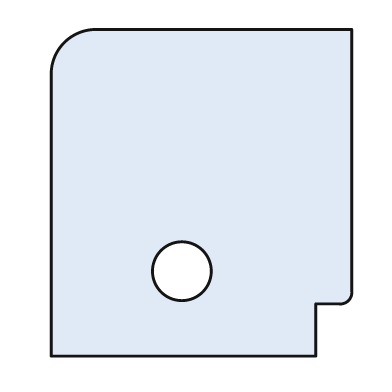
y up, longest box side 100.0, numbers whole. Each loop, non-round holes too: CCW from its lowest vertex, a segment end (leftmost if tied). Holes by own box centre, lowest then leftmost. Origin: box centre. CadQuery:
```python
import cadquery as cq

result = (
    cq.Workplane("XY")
    .moveTo(-46.0, -50.0)
    .lineTo(35.0, -50.0)
    .lineTo(35.0, -34.0)
    .lineTo(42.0, -34.0)
    .threePointArc((45.0, -33.0), (46.0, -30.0))
    .lineTo(46.0, 50.0)
    .lineTo(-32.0, 50.0)
    .threePointArc((-42.0, 46.0), (-46.0, 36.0))
    .close()
    .moveTo(-6.0, -24.0)
    .circle(9.0)
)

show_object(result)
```